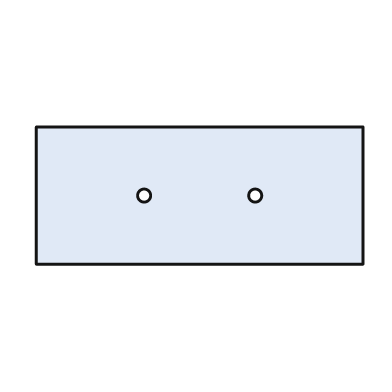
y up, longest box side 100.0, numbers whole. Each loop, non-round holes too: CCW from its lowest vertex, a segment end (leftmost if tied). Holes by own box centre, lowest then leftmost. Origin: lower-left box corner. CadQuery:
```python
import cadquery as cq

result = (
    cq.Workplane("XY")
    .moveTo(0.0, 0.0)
    .lineTo(100.0, 0.0)
    .lineTo(100.0, 42.0)
    .lineTo(0.0, 42.0)
    .close()
    .moveTo(33.0, 21.0)
    .circle(2.0)
    .moveTo(67.0, 21.0)
    .circle(2.0)
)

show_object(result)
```